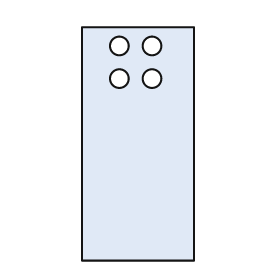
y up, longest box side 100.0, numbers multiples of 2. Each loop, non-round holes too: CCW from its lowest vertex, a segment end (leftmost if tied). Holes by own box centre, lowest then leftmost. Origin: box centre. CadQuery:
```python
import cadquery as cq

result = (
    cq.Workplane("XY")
    .moveTo(-24.0, -50.0)
    .lineTo(24.0, -50.0)
    .lineTo(24.0, 50.0)
    .lineTo(-24.0, 50.0)
    .close()
    .moveTo(-8.0, 28.0)
    .circle(4.0)
    .moveTo(6.0, 28.0)
    .circle(4.0)
    .moveTo(-8.0, 42.0)
    .circle(4.0)
    .moveTo(6.0, 42.0)
    .circle(4.0)
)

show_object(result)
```